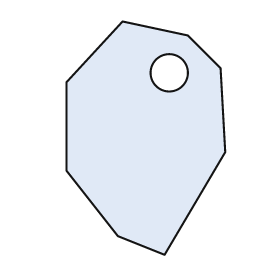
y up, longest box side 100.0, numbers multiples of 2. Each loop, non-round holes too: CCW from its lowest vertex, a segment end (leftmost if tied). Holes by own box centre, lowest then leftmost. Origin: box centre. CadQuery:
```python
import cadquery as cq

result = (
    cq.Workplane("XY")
    .moveTo(8.0, -50.0)
    .lineTo(34.0, -6.0)
    .lineTo(32.0, 30.0)
    .lineTo(18.0, 44.0)
    .lineTo(-10.0, 50.0)
    .lineTo(-34.0, 24.0)
    .lineTo(-34.0, -14.0)
    .lineTo(-12.0, -42.0)
    .close()
    .moveTo(10.0, 28.0)
    .circle(8.0)
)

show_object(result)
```